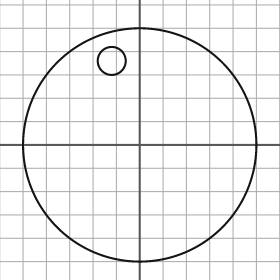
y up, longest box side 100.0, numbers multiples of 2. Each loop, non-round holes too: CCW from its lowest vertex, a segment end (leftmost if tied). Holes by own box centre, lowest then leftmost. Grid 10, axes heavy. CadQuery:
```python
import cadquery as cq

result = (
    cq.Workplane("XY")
    .moveTo(0.0, 0.0)
    .circle(50.0)
    .moveTo(-12.0, 36.0)
    .circle(6.0)
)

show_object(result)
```